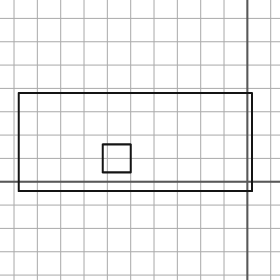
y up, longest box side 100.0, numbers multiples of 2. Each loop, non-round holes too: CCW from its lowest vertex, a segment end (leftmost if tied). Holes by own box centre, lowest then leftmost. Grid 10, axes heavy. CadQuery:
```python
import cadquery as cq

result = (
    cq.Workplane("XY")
    .moveTo(-98.0, -4.0)
    .lineTo(2.0, -4.0)
    .lineTo(2.0, 38.0)
    .lineTo(-98.0, 38.0)
    .close()
    .moveTo(-62.0, 4.0)
    .lineTo(-50.0, 4.0)
    .lineTo(-50.0, 16.0)
    .lineTo(-62.0, 16.0)
    .close()
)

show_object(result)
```